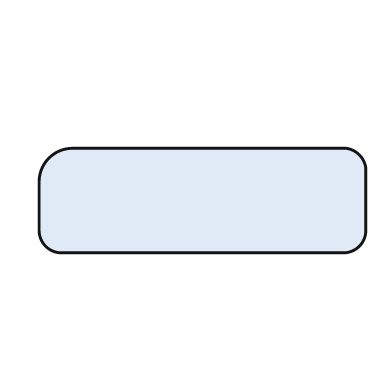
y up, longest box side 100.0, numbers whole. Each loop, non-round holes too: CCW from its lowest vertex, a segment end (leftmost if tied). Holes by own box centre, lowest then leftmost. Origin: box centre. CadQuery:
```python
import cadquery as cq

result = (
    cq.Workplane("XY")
    .moveTo(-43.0, -16.0)
    .lineTo(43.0, -16.0)
    .threePointArc((48.0, -14.0), (50.0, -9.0))
    .lineTo(50.0, 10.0)
    .threePointArc((48.0, 14.0), (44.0, 16.0))
    .lineTo(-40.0, 16.0)
    .threePointArc((-47.0, 13.0), (-50.0, 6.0))
    .lineTo(-50.0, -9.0)
    .threePointArc((-48.0, -14.0), (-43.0, -16.0))
    .close()
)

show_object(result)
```